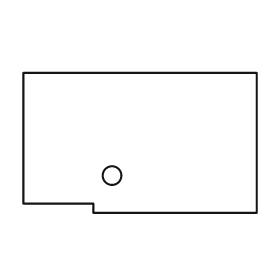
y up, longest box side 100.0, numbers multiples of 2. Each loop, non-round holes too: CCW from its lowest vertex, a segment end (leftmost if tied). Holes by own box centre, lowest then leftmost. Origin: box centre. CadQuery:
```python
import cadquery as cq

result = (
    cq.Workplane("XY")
    .moveTo(-20.0, -30.0)
    .lineTo(50.0, -30.0)
    .lineTo(50.0, 30.0)
    .lineTo(-50.0, 30.0)
    .lineTo(-50.0, -26.0)
    .lineTo(-20.0, -26.0)
    .close()
    .moveTo(-12.0, -14.0)
    .circle(4.0)
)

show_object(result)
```